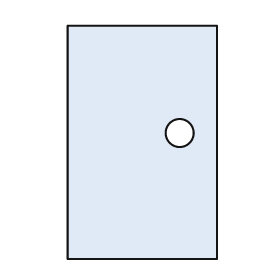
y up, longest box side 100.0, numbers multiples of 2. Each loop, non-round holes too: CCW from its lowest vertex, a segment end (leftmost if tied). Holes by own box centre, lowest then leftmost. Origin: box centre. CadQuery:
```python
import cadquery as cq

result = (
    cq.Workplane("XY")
    .moveTo(-32.0, -50.0)
    .lineTo(32.0, -50.0)
    .lineTo(32.0, 50.0)
    .lineTo(-32.0, 50.0)
    .close()
    .moveTo(16.0, 4.0)
    .circle(6.0)
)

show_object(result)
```